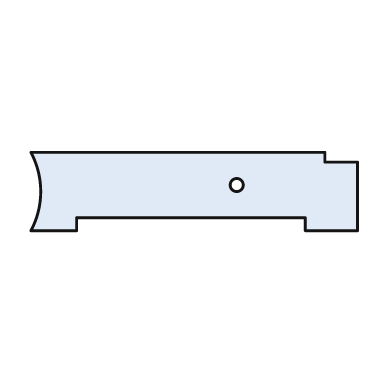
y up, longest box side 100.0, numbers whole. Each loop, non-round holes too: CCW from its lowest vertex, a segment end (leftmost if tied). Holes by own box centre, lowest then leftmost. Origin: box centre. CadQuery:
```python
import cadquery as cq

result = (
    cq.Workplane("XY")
    .moveTo(-50.0, -12.0)
    .lineTo(-36.0, -12.0)
    .lineTo(-36.0, -8.0)
    .lineTo(34.0, -8.0)
    .lineTo(34.0, -12.0)
    .lineTo(50.0, -12.0)
    .lineTo(50.0, 9.0)
    .lineTo(40.0, 9.0)
    .lineTo(40.0, 12.0)
    .lineTo(-50.0, 12.0)
    .threePointArc((-47.0, 0.0), (-50.0, -12.0))
    .close()
    .moveTo(13.0, 2.0)
    .circle(2.0)
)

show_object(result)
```